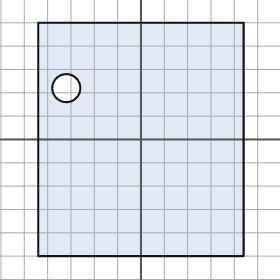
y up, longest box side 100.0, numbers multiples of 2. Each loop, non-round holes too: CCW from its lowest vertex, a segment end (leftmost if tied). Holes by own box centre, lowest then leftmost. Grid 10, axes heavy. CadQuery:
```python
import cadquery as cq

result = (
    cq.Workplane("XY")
    .moveTo(-44.0, -50.0)
    .lineTo(44.0, -50.0)
    .lineTo(44.0, 50.0)
    .lineTo(-44.0, 50.0)
    .close()
    .moveTo(-32.0, 22.0)
    .circle(6.0)
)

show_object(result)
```